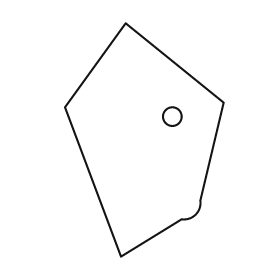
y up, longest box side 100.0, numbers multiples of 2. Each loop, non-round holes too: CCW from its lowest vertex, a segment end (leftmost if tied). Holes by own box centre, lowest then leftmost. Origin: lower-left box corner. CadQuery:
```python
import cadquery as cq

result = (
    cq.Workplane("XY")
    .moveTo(24.0, 0.0)
    .lineTo(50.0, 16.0)
    .threePointArc((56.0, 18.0), (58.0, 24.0))
    .lineTo(68.0, 66.0)
    .lineTo(26.0, 100.0)
    .lineTo(0.0, 64.0)
    .close()
    .moveTo(46.0, 60.0)
    .circle(4.0)
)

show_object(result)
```